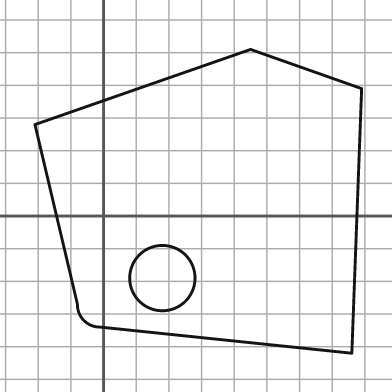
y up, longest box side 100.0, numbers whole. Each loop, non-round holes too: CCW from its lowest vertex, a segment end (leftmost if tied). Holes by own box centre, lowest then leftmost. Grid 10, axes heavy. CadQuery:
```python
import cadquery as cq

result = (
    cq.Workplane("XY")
    .moveTo(76.0, -42.0)
    .lineTo(79.0, 39.0)
    .lineTo(45.0, 51.0)
    .lineTo(-21.0, 28.0)
    .lineTo(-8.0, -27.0)
    .threePointArc((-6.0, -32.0), (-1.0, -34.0))
    .close()
    .moveTo(18.0, -19.0)
    .circle(10.0)
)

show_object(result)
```